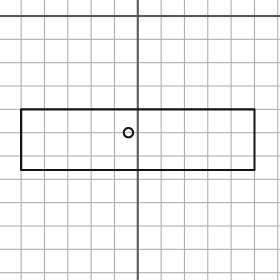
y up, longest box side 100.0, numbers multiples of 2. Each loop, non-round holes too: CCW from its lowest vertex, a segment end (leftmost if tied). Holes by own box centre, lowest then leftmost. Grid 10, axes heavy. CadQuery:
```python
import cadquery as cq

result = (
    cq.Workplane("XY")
    .moveTo(-50.0, -66.0)
    .lineTo(50.0, -66.0)
    .lineTo(50.0, -40.0)
    .lineTo(-50.0, -40.0)
    .close()
    .moveTo(-4.0, -50.0)
    .circle(2.0)
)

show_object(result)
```